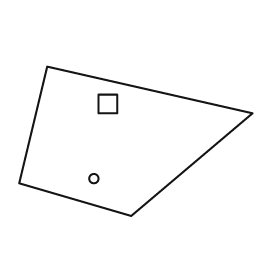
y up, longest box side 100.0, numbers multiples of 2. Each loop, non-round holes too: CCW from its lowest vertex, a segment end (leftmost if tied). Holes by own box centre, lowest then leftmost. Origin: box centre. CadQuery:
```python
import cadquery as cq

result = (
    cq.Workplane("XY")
    .moveTo(-2.0, -32.0)
    .lineTo(50.0, 12.0)
    .lineTo(-38.0, 32.0)
    .lineTo(-50.0, -18.0)
    .close()
    .moveTo(-18.0, -16.0)
    .circle(2.0)
    .moveTo(-16.0, 12.0)
    .lineTo(-8.0, 12.0)
    .lineTo(-8.0, 20.0)
    .lineTo(-16.0, 20.0)
    .close()
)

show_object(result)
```